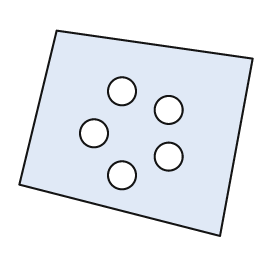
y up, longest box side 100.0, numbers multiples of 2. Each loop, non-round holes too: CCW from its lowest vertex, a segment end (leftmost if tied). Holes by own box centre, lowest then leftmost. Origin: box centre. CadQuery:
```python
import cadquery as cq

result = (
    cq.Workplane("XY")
    .moveTo(36.0, -44.0)
    .lineTo(50.0, 32.0)
    .lineTo(-34.0, 44.0)
    .lineTo(-50.0, -22.0)
    .close()
    .moveTo(-6.0, -18.0)
    .circle(6.0)
    .moveTo(14.0, -10.0)
    .circle(6.0)
    .moveTo(-18.0, 0.0)
    .circle(6.0)
    .moveTo(14.0, 10.0)
    .circle(6.0)
    .moveTo(-6.0, 18.0)
    .circle(6.0)
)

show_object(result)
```